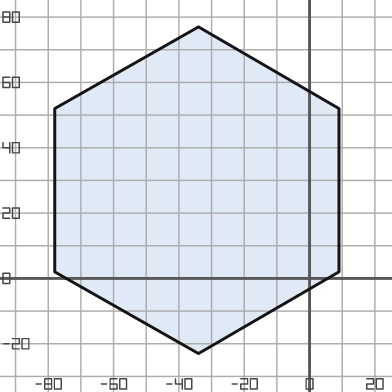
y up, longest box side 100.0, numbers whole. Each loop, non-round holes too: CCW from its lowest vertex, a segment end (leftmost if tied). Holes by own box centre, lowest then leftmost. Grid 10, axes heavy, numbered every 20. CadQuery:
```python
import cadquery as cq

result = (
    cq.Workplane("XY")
    .moveTo(-34.0, -23.0)
    .lineTo(9.0, 2.0)
    .lineTo(9.0, 52.0)
    .lineTo(-34.0, 77.0)
    .lineTo(-78.0, 52.0)
    .lineTo(-78.0, 2.0)
    .close()
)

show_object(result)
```